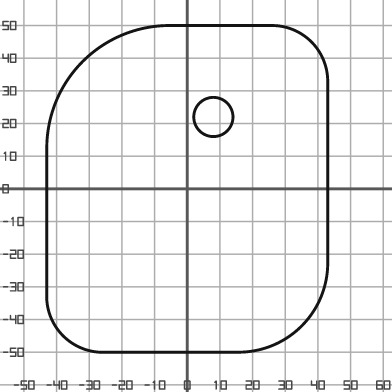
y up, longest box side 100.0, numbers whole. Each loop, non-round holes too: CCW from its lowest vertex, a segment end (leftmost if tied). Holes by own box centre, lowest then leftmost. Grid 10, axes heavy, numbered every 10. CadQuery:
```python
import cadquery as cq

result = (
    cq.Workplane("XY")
    .moveTo(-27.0, -50.0)
    .lineTo(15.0, -50.0)
    .threePointArc((35.0, -42.0), (43.0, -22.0))
    .lineTo(43.0, 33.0)
    .threePointArc((38.0, 45.0), (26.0, 50.0))
    .lineTo(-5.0, 50.0)
    .threePointArc((-32.0, 39.0), (-43.0, 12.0))
    .lineTo(-43.0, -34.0)
    .threePointArc((-38.0, -45.0), (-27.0, -50.0))
    .close()
    .moveTo(8.0, 22.0)
    .circle(6.0)
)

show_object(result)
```